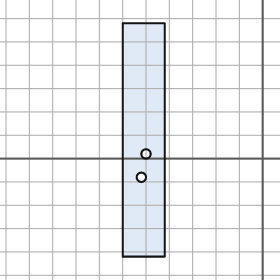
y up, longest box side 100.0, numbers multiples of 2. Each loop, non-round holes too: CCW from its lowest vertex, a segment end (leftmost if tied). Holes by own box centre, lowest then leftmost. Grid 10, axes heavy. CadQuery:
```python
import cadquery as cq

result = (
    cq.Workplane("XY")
    .moveTo(-60.0, -42.0)
    .lineTo(-42.0, -42.0)
    .lineTo(-42.0, 58.0)
    .lineTo(-60.0, 58.0)
    .close()
    .moveTo(-52.0, -8.0)
    .circle(2.0)
    .moveTo(-50.0, 2.0)
    .circle(2.0)
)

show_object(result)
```